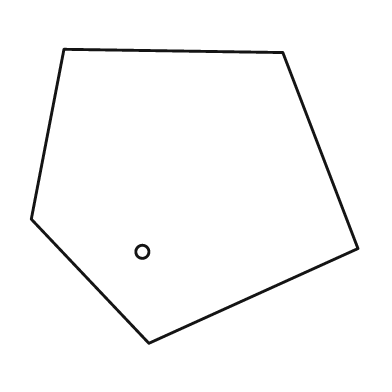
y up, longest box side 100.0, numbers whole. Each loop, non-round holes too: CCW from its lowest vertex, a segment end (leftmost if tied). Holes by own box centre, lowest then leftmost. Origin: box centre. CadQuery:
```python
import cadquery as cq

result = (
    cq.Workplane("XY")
    .moveTo(-14.0, -45.0)
    .lineTo(50.0, -16.0)
    .lineTo(27.0, 44.0)
    .lineTo(-40.0, 45.0)
    .lineTo(-50.0, -7.0)
    .close()
    .moveTo(-16.0, -17.0)
    .circle(2.0)
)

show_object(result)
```